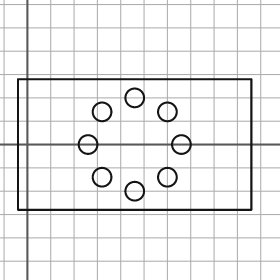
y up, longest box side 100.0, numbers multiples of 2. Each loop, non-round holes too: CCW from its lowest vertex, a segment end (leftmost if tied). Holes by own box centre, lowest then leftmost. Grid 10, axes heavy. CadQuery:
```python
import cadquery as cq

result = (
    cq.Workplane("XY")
    .moveTo(-4.0, -28.0)
    .lineTo(96.0, -28.0)
    .lineTo(96.0, 28.0)
    .lineTo(-4.0, 28.0)
    .close()
    .moveTo(46.0, -20.0)
    .circle(4.0)
    .moveTo(32.0, -14.0)
    .circle(4.0)
    .moveTo(60.0, -14.0)
    .circle(4.0)
    .moveTo(26.0, 0.0)
    .circle(4.0)
    .moveTo(66.0, 0.0)
    .circle(4.0)
    .moveTo(32.0, 14.0)
    .circle(4.0)
    .moveTo(60.0, 14.0)
    .circle(4.0)
    .moveTo(46.0, 20.0)
    .circle(4.0)
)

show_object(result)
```